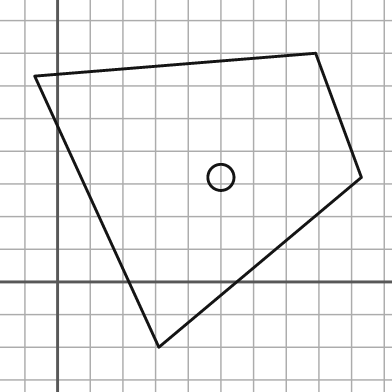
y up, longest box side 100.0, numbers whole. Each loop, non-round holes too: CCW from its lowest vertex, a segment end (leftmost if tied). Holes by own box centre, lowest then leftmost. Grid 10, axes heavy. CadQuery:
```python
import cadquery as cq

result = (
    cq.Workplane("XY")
    .moveTo(31.0, -20.0)
    .lineTo(93.0, 32.0)
    .lineTo(79.0, 70.0)
    .lineTo(-7.0, 63.0)
    .close()
    .moveTo(50.0, 32.0)
    .circle(4.0)
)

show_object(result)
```